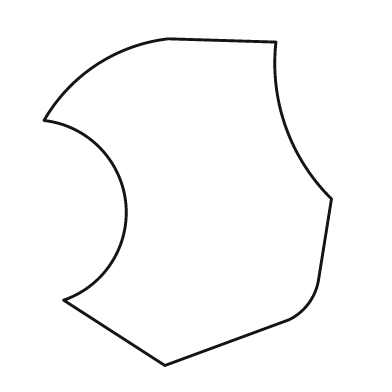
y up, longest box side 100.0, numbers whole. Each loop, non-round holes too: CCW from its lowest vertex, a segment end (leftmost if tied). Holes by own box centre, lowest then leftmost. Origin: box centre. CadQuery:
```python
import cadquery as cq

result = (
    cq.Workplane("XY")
    .moveTo(-7.0, -50.0)
    .lineTo(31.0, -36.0)
    .threePointArc((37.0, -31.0), (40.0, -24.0))
    .lineTo(44.0, 1.0)
    .threePointArc((30.0, 23.0), (27.0, 49.0))
    .lineTo(-6.0, 50.0)
    .threePointArc((-28.0, 42.0), (-44.0, 25.0))
    .threePointArc((-19.0, 0.0), (-38.0, -30.0))
    .close()
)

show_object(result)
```